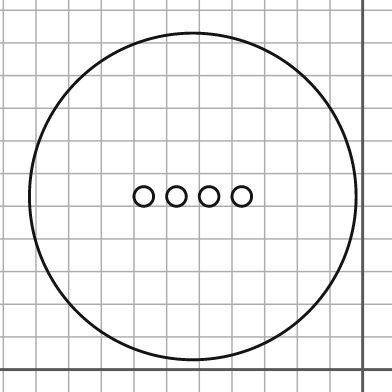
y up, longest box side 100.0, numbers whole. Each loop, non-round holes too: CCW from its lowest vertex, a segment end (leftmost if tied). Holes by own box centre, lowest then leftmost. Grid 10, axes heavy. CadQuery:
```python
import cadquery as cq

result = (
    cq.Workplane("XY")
    .moveTo(-52.0, 53.0)
    .circle(50.0)
    .moveTo(-67.0, 53.0)
    .circle(3.0)
    .moveTo(-57.0, 53.0)
    .circle(3.0)
    .moveTo(-47.0, 53.0)
    .circle(3.0)
    .moveTo(-37.0, 53.0)
    .circle(3.0)
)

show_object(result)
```